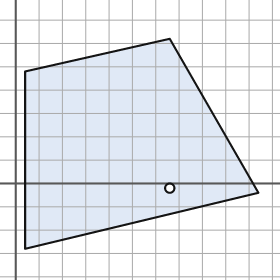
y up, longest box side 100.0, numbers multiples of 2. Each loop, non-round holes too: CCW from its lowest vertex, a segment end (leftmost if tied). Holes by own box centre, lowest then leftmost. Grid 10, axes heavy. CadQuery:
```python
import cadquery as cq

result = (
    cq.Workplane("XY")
    .moveTo(4.0, -28.0)
    .lineTo(104.0, -4.0)
    .lineTo(66.0, 62.0)
    .lineTo(4.0, 48.0)
    .close()
    .moveTo(66.0, -2.0)
    .circle(2.0)
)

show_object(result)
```